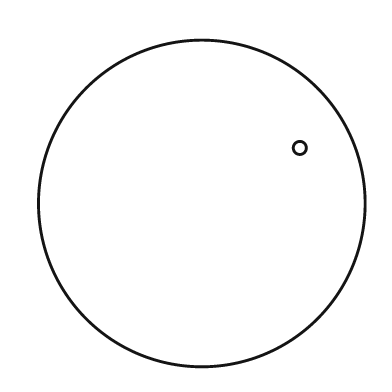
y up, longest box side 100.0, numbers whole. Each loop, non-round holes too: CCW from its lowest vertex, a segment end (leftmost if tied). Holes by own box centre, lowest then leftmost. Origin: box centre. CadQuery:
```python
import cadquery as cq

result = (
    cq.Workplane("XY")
    .moveTo(0.0, 0.0)
    .circle(50.0)
    .moveTo(30.0, 17.0)
    .circle(2.0)
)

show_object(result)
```